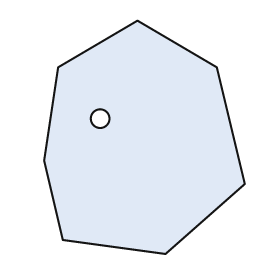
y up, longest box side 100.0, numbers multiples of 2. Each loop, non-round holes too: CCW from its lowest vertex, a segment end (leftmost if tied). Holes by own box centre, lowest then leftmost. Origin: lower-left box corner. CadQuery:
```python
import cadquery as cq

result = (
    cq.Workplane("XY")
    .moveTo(52.0, 0.0)
    .lineTo(86.0, 30.0)
    .lineTo(74.0, 80.0)
    .lineTo(40.0, 100.0)
    .lineTo(6.0, 80.0)
    .lineTo(0.0, 40.0)
    .lineTo(8.0, 6.0)
    .close()
    .moveTo(24.0, 58.0)
    .circle(4.0)
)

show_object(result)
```